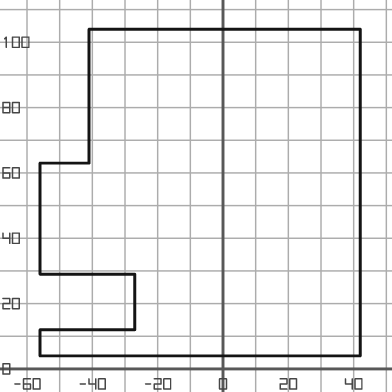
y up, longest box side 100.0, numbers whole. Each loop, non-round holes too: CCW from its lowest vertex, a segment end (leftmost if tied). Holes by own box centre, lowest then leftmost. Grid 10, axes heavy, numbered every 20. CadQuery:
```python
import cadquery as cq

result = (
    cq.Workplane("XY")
    .moveTo(-56.0, 4.0)
    .lineTo(42.0, 4.0)
    .lineTo(42.0, 104.0)
    .lineTo(-41.0, 104.0)
    .lineTo(-41.0, 63.0)
    .lineTo(-56.0, 63.0)
    .lineTo(-56.0, 29.0)
    .lineTo(-27.0, 29.0)
    .lineTo(-27.0, 12.0)
    .lineTo(-56.0, 12.0)
    .close()
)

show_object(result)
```